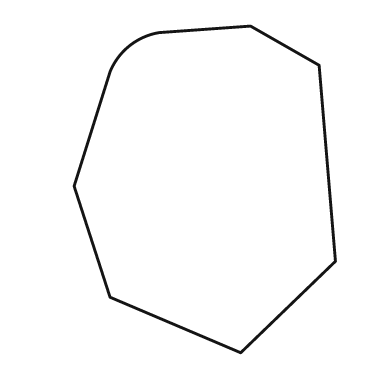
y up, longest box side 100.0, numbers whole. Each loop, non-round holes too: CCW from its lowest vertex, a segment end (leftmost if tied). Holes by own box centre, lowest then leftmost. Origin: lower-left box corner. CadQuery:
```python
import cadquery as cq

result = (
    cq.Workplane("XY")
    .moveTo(51.0, 0.0)
    .lineTo(80.0, 28.0)
    .lineTo(75.0, 88.0)
    .lineTo(54.0, 100.0)
    .lineTo(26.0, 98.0)
    .threePointArc((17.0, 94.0), (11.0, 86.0))
    .lineTo(0.0, 51.0)
    .lineTo(11.0, 17.0)
    .close()
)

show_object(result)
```